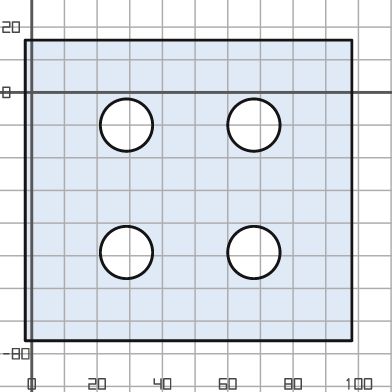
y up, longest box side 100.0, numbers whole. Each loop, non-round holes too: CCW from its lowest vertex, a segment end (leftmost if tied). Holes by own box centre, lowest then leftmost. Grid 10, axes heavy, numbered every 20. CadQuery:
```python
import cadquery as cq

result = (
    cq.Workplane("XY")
    .moveTo(-2.0, -76.0)
    .lineTo(98.0, -76.0)
    .lineTo(98.0, 16.0)
    .lineTo(-2.0, 16.0)
    .close()
    .moveTo(29.0, -49.0)
    .circle(8.0)
    .moveTo(68.0, -49.0)
    .circle(8.0)
    .moveTo(29.0, -10.0)
    .circle(8.0)
    .moveTo(68.0, -10.0)
    .circle(8.0)
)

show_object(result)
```